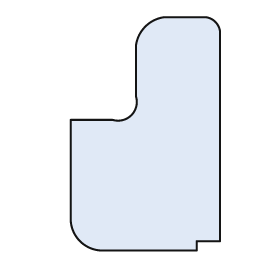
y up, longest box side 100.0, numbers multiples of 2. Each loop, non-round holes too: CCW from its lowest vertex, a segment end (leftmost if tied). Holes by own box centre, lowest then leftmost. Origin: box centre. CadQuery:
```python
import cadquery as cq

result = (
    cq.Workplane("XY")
    .moveTo(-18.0, -50.0)
    .lineTo(22.0, -50.0)
    .lineTo(22.0, -46.0)
    .lineTo(32.0, -46.0)
    .lineTo(32.0, 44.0)
    .threePointArc((30.0, 48.0), (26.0, 50.0))
    .lineTo(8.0, 50.0)
    .threePointArc((0.0, 46.0), (-4.0, 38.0))
    .lineTo(-4.0, 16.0)
    .threePointArc((-6.0, 8.0), (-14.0, 6.0))
    .lineTo(-32.0, 6.0)
    .lineTo(-32.0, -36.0)
    .threePointArc((-28.0, -46.0), (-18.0, -50.0))
    .close()
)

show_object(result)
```